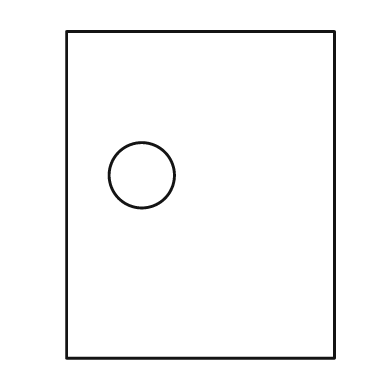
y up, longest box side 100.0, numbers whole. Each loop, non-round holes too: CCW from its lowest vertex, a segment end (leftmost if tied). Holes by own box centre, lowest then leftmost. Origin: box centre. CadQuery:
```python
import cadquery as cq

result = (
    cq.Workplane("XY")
    .moveTo(-41.0, -50.0)
    .lineTo(41.0, -50.0)
    .lineTo(41.0, 50.0)
    .lineTo(-41.0, 50.0)
    .close()
    .moveTo(-18.0, 6.0)
    .circle(10.0)
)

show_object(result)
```